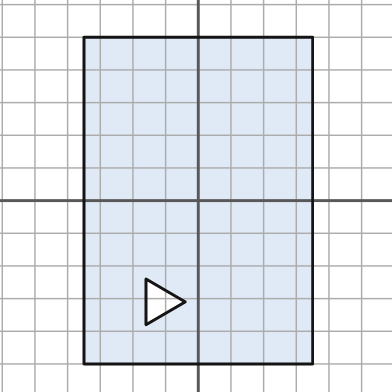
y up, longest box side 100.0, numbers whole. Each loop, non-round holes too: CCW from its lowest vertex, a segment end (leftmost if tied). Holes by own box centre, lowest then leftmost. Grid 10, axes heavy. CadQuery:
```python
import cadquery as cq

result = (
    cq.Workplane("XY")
    .moveTo(-35.0, -50.0)
    .lineTo(35.0, -50.0)
    .lineTo(35.0, 50.0)
    .lineTo(-35.0, 50.0)
    .close()
    .moveTo(-16.0, -38.0)
    .lineTo(-4.0, -31.0)
    .lineTo(-16.0, -24.0)
    .close()
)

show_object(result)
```